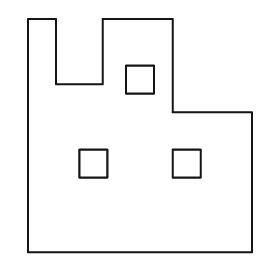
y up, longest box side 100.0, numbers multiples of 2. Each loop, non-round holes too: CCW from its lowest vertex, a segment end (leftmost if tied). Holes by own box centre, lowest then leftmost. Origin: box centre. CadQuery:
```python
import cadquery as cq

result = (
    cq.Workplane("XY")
    .moveTo(-48.0, -50.0)
    .lineTo(48.0, -50.0)
    .lineTo(48.0, 10.0)
    .lineTo(14.0, 10.0)
    .lineTo(14.0, 50.0)
    .lineTo(-16.0, 50.0)
    .lineTo(-16.0, 22.0)
    .lineTo(-36.0, 22.0)
    .lineTo(-36.0, 50.0)
    .lineTo(-48.0, 50.0)
    .close()
    .moveTo(-26.0, -18.0)
    .lineTo(-14.0, -18.0)
    .lineTo(-14.0, -6.0)
    .lineTo(-26.0, -6.0)
    .close()
    .moveTo(14.0, -18.0)
    .lineTo(26.0, -18.0)
    .lineTo(26.0, -6.0)
    .lineTo(14.0, -6.0)
    .close()
    .moveTo(-6.0, 18.0)
    .lineTo(6.0, 18.0)
    .lineTo(6.0, 30.0)
    .lineTo(-6.0, 30.0)
    .close()
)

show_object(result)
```